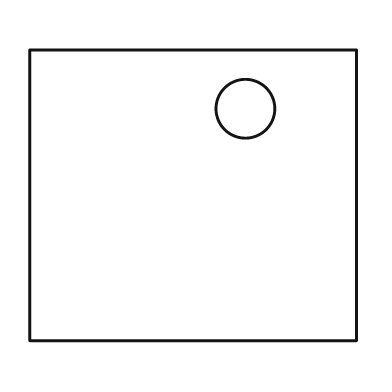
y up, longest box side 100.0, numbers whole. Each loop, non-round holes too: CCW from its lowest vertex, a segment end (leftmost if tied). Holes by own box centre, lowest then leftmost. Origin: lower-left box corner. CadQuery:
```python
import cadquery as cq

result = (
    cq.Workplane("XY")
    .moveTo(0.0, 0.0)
    .lineTo(100.0, 0.0)
    .lineTo(100.0, 89.0)
    .lineTo(0.0, 89.0)
    .close()
    .moveTo(66.0, 71.0)
    .circle(9.0)
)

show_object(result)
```